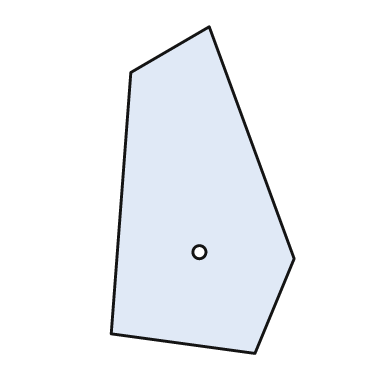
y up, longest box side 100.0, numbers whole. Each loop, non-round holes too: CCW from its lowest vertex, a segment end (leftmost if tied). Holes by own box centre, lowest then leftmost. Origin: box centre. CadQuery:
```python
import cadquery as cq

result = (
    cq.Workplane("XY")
    .moveTo(16.0, -50.0)
    .lineTo(28.0, -21.0)
    .lineTo(2.0, 50.0)
    .lineTo(-22.0, 36.0)
    .lineTo(-28.0, -44.0)
    .close()
    .moveTo(-1.0, -19.0)
    .circle(2.0)
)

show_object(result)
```